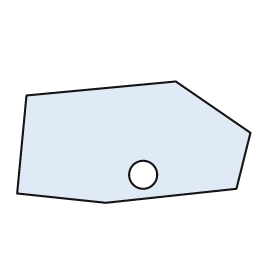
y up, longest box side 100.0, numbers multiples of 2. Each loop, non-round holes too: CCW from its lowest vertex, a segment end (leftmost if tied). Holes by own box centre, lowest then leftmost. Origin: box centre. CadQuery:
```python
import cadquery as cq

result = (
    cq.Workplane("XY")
    .moveTo(-12.0, -26.0)
    .lineTo(44.0, -20.0)
    .lineTo(50.0, 4.0)
    .lineTo(18.0, 26.0)
    .lineTo(-46.0, 20.0)
    .lineTo(-50.0, -22.0)
    .close()
    .moveTo(4.0, -14.0)
    .circle(6.0)
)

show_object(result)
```